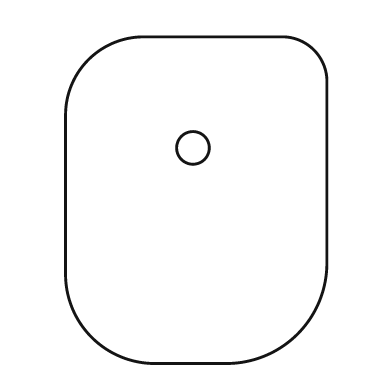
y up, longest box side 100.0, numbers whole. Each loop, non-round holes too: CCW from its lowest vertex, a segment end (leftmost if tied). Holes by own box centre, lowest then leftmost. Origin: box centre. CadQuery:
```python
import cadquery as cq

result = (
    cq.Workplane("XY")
    .moveTo(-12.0, -50.0)
    .lineTo(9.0, -50.0)
    .threePointArc((31.0, -41.0), (40.0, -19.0))
    .lineTo(40.0, 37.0)
    .threePointArc((36.0, 46.0), (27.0, 50.0))
    .lineTo(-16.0, 50.0)
    .threePointArc((-33.0, 43.0), (-40.0, 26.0))
    .lineTo(-40.0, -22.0)
    .threePointArc((-32.0, -42.0), (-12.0, -50.0))
    .close()
    .moveTo(-1.0, 16.0)
    .circle(5.0)
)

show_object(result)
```